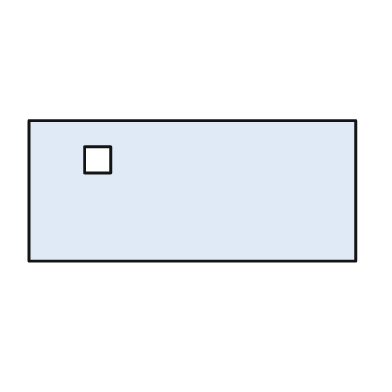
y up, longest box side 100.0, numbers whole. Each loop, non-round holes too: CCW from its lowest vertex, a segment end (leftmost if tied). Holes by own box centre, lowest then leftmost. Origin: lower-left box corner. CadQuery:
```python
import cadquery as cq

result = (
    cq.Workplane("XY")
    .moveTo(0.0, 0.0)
    .lineTo(100.0, 0.0)
    .lineTo(100.0, 43.0)
    .lineTo(0.0, 43.0)
    .close()
    .moveTo(17.0, 27.0)
    .lineTo(25.0, 27.0)
    .lineTo(25.0, 35.0)
    .lineTo(17.0, 35.0)
    .close()
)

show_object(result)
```